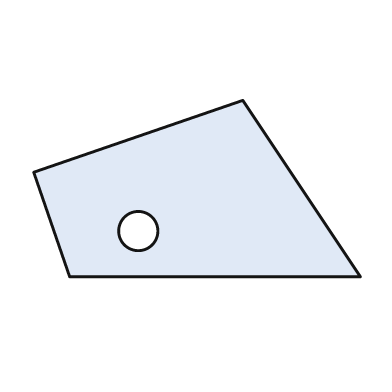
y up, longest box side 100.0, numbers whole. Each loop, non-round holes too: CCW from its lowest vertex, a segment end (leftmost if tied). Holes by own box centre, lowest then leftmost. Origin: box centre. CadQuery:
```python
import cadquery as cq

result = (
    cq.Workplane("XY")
    .moveTo(-39.0, -27.0)
    .lineTo(50.0, -27.0)
    .lineTo(14.0, 27.0)
    .lineTo(-50.0, 5.0)
    .close()
    .moveTo(-18.0, -13.0)
    .circle(6.0)
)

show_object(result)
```